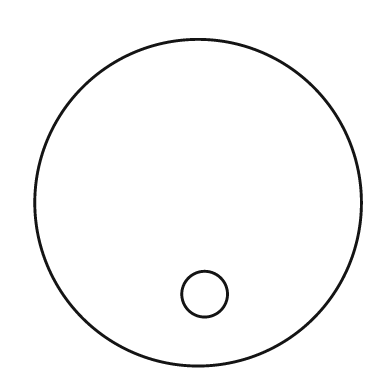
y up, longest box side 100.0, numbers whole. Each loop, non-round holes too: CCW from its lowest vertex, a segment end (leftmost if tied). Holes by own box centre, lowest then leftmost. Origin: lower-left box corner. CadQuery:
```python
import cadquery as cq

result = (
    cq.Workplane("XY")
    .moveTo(50.0, 50.0)
    .circle(50.0)
    .moveTo(52.0, 22.0)
    .circle(7.0)
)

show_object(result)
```